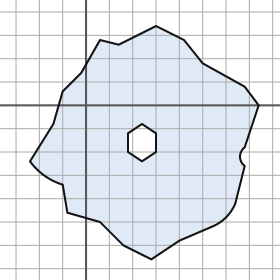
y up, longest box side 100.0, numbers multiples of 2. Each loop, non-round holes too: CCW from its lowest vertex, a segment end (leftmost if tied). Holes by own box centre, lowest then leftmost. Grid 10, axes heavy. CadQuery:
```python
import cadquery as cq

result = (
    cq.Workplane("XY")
    .moveTo(28.0, -66.0)
    .lineTo(40.0, -58.0)
    .lineTo(54.0, -52.0)
    .threePointArc((60.0, -48.0), (64.0, -42.0))
    .lineTo(68.0, -26.0)
    .threePointArc((66.0, -22.0), (68.0, -18.0))
    .lineTo(74.0, 0.0)
    .lineTo(68.0, 8.0)
    .lineTo(50.0, 18.0)
    .lineTo(42.0, 28.0)
    .lineTo(30.0, 34.0)
    .lineTo(14.0, 26.0)
    .lineTo(6.0, 28.0)
    .lineTo(-2.0, 14.0)
    .lineTo(-10.0, 6.0)
    .lineTo(-14.0, -8.0)
    .lineTo(-24.0, -24.0)
    .threePointArc((-18.0, -30.0), (-10.0, -34.0))
    .lineTo(-8.0, -46.0)
    .lineTo(6.0, -50.0)
    .lineTo(16.0, -60.0)
    .close()
    .moveTo(24.0, -24.0)
    .lineTo(30.0, -20.0)
    .lineTo(30.0, -12.0)
    .lineTo(24.0, -8.0)
    .lineTo(18.0, -12.0)
    .lineTo(18.0, -20.0)
    .close()
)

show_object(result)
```